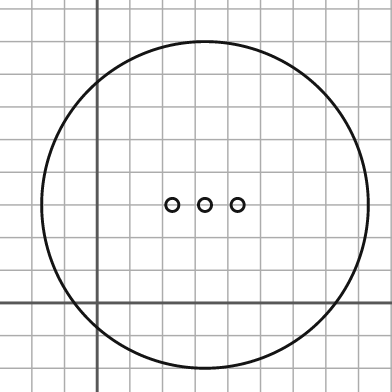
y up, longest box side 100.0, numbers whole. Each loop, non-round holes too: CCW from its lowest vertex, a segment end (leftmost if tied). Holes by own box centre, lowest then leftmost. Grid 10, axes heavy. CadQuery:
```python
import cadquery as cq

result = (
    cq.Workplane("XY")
    .moveTo(33.0, 30.0)
    .circle(50.0)
    .moveTo(23.0, 30.0)
    .circle(2.0)
    .moveTo(33.0, 30.0)
    .circle(2.0)
    .moveTo(43.0, 30.0)
    .circle(2.0)
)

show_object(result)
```